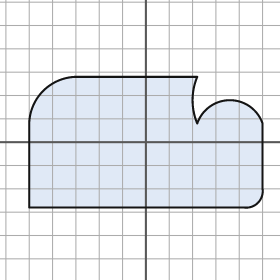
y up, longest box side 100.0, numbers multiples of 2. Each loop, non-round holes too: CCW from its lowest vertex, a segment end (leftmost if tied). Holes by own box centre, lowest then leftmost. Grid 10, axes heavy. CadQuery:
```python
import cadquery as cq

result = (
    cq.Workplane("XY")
    .moveTo(-50.0, -28.0)
    .lineTo(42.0, -28.0)
    .threePointArc((48.0, -26.0), (50.0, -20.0))
    .lineTo(50.0, 8.0)
    .threePointArc((36.0, 18.0), (22.0, 8.0))
    .threePointArc((20.0, 18.0), (22.0, 28.0))
    .lineTo(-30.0, 28.0)
    .threePointArc((-44.0, 22.0), (-50.0, 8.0))
    .close()
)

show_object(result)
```